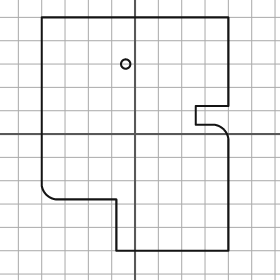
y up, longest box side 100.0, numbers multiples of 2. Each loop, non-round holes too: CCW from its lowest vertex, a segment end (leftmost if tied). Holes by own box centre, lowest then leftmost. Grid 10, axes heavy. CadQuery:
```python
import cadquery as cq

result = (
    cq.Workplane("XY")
    .moveTo(-8.0, -50.0)
    .lineTo(40.0, -50.0)
    .lineTo(40.0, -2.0)
    .threePointArc((38.0, 2.0), (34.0, 4.0))
    .lineTo(26.0, 4.0)
    .lineTo(26.0, 12.0)
    .lineTo(40.0, 12.0)
    .lineTo(40.0, 50.0)
    .lineTo(-40.0, 50.0)
    .lineTo(-40.0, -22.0)
    .threePointArc((-38.0, -26.0), (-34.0, -28.0))
    .lineTo(-8.0, -28.0)
    .close()
    .moveTo(-4.0, 30.0)
    .circle(2.0)
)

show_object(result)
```